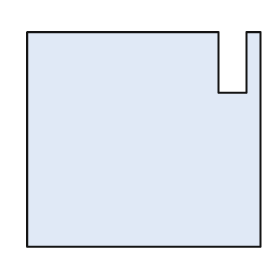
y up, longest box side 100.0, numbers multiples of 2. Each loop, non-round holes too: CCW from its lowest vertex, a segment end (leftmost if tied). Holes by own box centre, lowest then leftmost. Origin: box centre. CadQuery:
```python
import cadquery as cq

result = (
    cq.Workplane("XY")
    .moveTo(-50.0, -46.0)
    .lineTo(50.0, -46.0)
    .lineTo(50.0, 46.0)
    .lineTo(44.0, 46.0)
    .lineTo(44.0, 20.0)
    .lineTo(32.0, 20.0)
    .lineTo(32.0, 46.0)
    .lineTo(-50.0, 46.0)
    .close()
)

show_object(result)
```